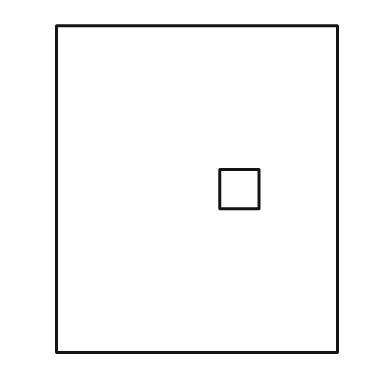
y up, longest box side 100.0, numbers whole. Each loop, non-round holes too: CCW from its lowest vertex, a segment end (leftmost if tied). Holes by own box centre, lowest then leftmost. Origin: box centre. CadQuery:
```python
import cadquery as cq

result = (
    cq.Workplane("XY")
    .moveTo(-43.0, -50.0)
    .lineTo(43.0, -50.0)
    .lineTo(43.0, 50.0)
    .lineTo(-43.0, 50.0)
    .close()
    .moveTo(7.0, -6.0)
    .lineTo(19.0, -6.0)
    .lineTo(19.0, 6.0)
    .lineTo(7.0, 6.0)
    .close()
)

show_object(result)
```